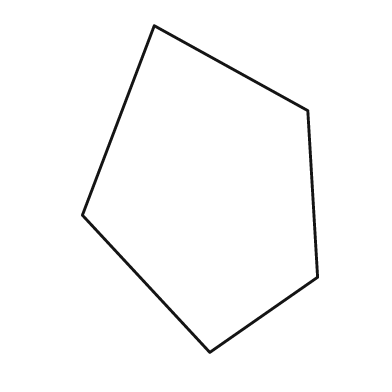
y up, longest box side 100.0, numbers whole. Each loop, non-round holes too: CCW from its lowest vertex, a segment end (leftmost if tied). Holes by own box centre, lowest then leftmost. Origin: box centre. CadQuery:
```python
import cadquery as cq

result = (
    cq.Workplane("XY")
    .moveTo(3.0, -50.0)
    .lineTo(36.0, -27.0)
    .lineTo(33.0, 24.0)
    .lineTo(-14.0, 50.0)
    .lineTo(-36.0, -8.0)
    .close()
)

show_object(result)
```